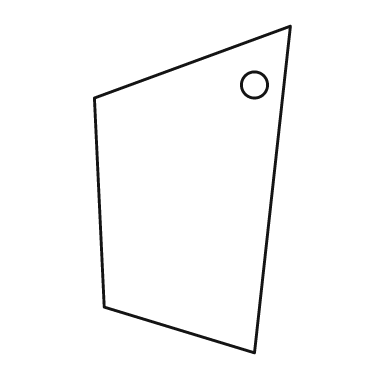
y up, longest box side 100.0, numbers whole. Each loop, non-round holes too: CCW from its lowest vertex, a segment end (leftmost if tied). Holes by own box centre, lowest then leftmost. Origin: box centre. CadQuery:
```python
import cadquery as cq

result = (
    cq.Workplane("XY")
    .moveTo(19.0, -50.0)
    .lineTo(30.0, 50.0)
    .lineTo(-30.0, 28.0)
    .lineTo(-27.0, -36.0)
    .close()
    .moveTo(19.0, 32.0)
    .circle(4.0)
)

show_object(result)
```